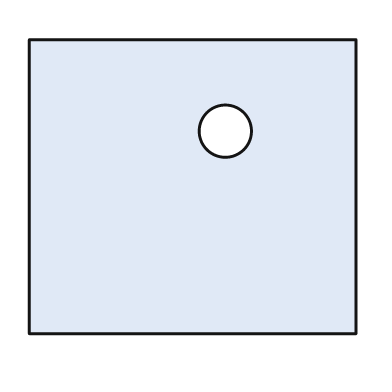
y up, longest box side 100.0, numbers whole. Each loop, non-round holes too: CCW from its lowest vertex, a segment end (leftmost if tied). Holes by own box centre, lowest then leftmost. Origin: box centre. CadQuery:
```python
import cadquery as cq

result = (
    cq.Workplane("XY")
    .moveTo(-50.0, -45.0)
    .lineTo(50.0, -45.0)
    .lineTo(50.0, 45.0)
    .lineTo(-50.0, 45.0)
    .close()
    .moveTo(10.0, 17.0)
    .circle(8.0)
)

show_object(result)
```